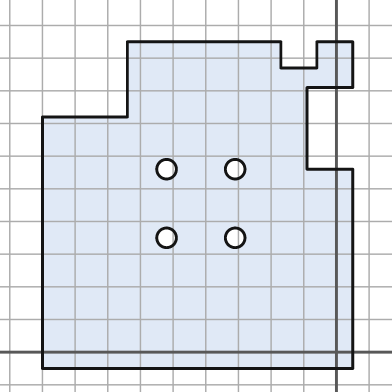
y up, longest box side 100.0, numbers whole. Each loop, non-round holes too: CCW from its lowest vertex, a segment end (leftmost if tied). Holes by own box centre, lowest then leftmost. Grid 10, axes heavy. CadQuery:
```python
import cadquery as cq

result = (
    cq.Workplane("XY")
    .moveTo(-90.0, -5.0)
    .lineTo(5.0, -5.0)
    .lineTo(5.0, 56.0)
    .lineTo(-9.0, 56.0)
    .lineTo(-9.0, 81.0)
    .lineTo(5.0, 81.0)
    .lineTo(5.0, 95.0)
    .lineTo(-6.0, 95.0)
    .lineTo(-6.0, 87.0)
    .lineTo(-17.0, 87.0)
    .lineTo(-17.0, 95.0)
    .lineTo(-64.0, 95.0)
    .lineTo(-64.0, 72.0)
    .lineTo(-90.0, 72.0)
    .close()
    .moveTo(-52.0, 35.0)
    .circle(3.0)
    .moveTo(-31.0, 35.0)
    .circle(3.0)
    .moveTo(-52.0, 56.0)
    .circle(3.0)
    .moveTo(-31.0, 56.0)
    .circle(3.0)
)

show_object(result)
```